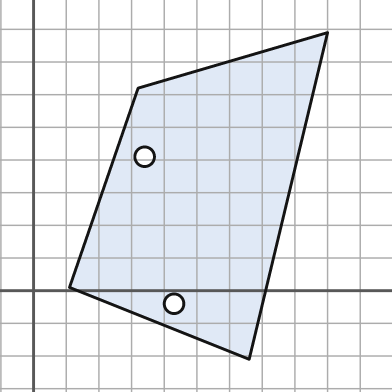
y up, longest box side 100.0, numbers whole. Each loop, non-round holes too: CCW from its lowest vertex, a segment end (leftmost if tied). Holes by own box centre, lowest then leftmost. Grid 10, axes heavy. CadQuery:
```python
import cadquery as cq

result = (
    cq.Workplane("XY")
    .moveTo(66.0, -21.0)
    .lineTo(90.0, 79.0)
    .lineTo(32.0, 62.0)
    .lineTo(11.0, 1.0)
    .close()
    .moveTo(43.0, -4.0)
    .circle(3.0)
    .moveTo(34.0, 41.0)
    .circle(3.0)
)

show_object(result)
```